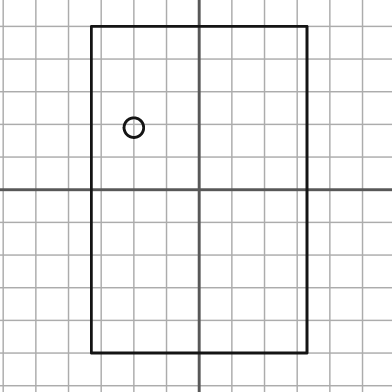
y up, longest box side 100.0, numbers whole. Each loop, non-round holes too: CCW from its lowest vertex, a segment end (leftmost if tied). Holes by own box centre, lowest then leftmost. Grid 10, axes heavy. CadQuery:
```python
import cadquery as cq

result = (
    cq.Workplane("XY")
    .moveTo(-33.0, -50.0)
    .lineTo(33.0, -50.0)
    .lineTo(33.0, 50.0)
    .lineTo(-33.0, 50.0)
    .close()
    .moveTo(-20.0, 19.0)
    .circle(3.0)
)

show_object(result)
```